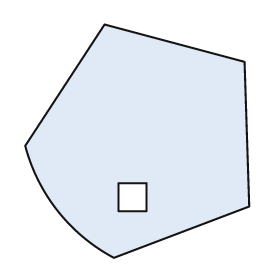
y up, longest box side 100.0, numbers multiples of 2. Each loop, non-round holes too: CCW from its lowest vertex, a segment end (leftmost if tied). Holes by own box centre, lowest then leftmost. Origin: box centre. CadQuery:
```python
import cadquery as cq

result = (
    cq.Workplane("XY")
    .moveTo(-10.0, -50.0)
    .lineTo(48.0, -28.0)
    .lineTo(46.0, 34.0)
    .lineTo(-14.0, 50.0)
    .lineTo(-48.0, -2.0)
    .threePointArc((-34.0, -30.0), (-10.0, -50.0))
    .close()
    .moveTo(-8.0, -30.0)
    .lineTo(4.0, -30.0)
    .lineTo(4.0, -18.0)
    .lineTo(-8.0, -18.0)
    .close()
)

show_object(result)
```